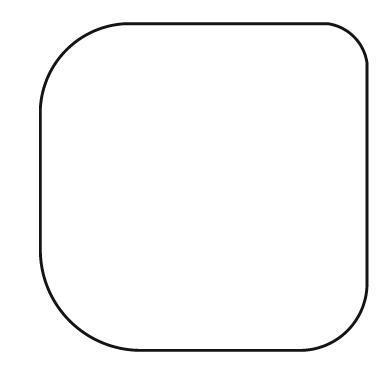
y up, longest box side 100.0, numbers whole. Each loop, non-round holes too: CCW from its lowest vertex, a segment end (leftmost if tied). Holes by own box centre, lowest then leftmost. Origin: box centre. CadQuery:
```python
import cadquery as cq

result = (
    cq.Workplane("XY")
    .moveTo(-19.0, -50.0)
    .lineTo(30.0, -50.0)
    .threePointArc((44.0, -44.0), (50.0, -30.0))
    .lineTo(50.0, 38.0)
    .threePointArc((46.0, 46.0), (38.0, 50.0))
    .lineTo(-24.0, 50.0)
    .threePointArc((-42.0, 42.0), (-50.0, 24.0))
    .lineTo(-50.0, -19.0)
    .threePointArc((-41.0, -41.0), (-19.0, -50.0))
    .close()
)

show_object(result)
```